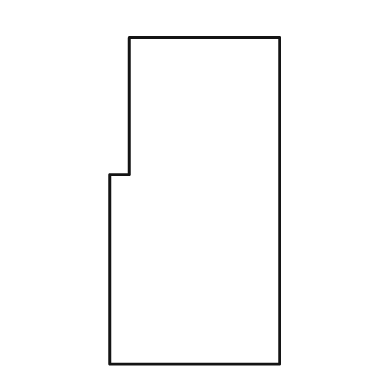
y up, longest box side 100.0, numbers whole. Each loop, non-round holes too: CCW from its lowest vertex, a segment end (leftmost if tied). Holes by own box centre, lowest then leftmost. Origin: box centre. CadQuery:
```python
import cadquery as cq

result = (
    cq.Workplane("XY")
    .moveTo(-26.0, -50.0)
    .lineTo(26.0, -50.0)
    .lineTo(26.0, 50.0)
    .lineTo(-20.0, 50.0)
    .lineTo(-20.0, 8.0)
    .lineTo(-26.0, 8.0)
    .close()
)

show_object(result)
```